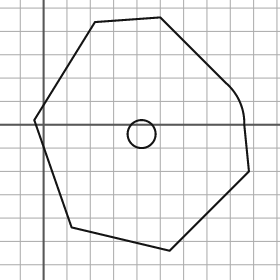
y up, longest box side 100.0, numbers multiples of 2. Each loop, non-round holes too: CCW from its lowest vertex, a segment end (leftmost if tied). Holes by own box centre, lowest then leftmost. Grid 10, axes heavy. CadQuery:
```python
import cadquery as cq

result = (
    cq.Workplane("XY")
    .moveTo(54.0, -54.0)
    .lineTo(88.0, -20.0)
    .lineTo(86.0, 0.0)
    .threePointArc((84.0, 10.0), (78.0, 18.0))
    .lineTo(50.0, 46.0)
    .lineTo(22.0, 44.0)
    .lineTo(-4.0, 2.0)
    .lineTo(12.0, -44.0)
    .close()
    .moveTo(42.0, -4.0)
    .circle(6.0)
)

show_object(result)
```